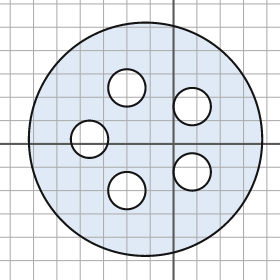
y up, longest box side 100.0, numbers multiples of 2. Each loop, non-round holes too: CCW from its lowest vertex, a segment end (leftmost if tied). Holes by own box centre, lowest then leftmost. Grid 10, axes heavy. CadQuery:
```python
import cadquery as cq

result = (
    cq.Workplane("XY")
    .moveTo(-12.0, 2.0)
    .circle(50.0)
    .moveTo(-20.0, -20.0)
    .circle(8.0)
    .moveTo(8.0, -12.0)
    .circle(8.0)
    .moveTo(-36.0, 2.0)
    .circle(8.0)
    .moveTo(8.0, 16.0)
    .circle(8.0)
    .moveTo(-20.0, 24.0)
    .circle(8.0)
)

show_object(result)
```